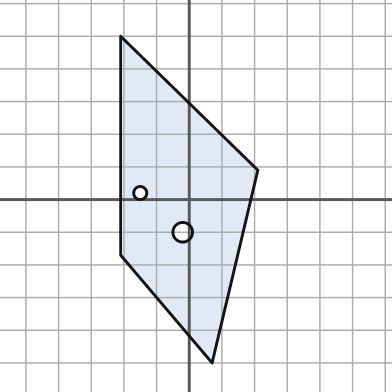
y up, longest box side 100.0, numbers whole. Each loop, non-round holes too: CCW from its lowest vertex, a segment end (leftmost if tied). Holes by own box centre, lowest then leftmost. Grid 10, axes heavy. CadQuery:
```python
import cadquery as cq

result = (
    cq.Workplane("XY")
    .moveTo(7.0, -50.0)
    .lineTo(21.0, 9.0)
    .lineTo(-21.0, 50.0)
    .lineTo(-21.0, -17.0)
    .close()
    .moveTo(-2.0, -10.0)
    .circle(3.0)
    .moveTo(-15.0, 2.0)
    .circle(2.0)
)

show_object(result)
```